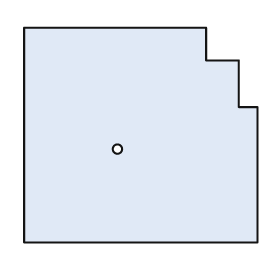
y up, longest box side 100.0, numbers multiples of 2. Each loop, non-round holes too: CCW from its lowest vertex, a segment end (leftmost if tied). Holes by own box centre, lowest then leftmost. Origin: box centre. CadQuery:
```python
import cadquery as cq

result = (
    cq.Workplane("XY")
    .moveTo(-50.0, -46.0)
    .lineTo(50.0, -46.0)
    .lineTo(50.0, 12.0)
    .lineTo(42.0, 12.0)
    .lineTo(42.0, 32.0)
    .lineTo(28.0, 32.0)
    .lineTo(28.0, 46.0)
    .lineTo(-50.0, 46.0)
    .close()
    .moveTo(-10.0, -6.0)
    .circle(2.0)
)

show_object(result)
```